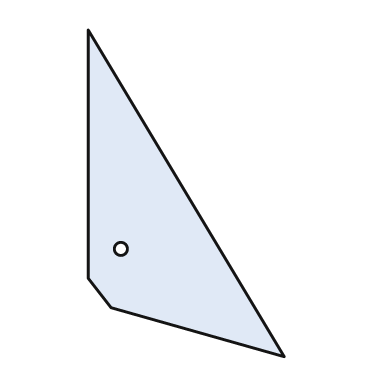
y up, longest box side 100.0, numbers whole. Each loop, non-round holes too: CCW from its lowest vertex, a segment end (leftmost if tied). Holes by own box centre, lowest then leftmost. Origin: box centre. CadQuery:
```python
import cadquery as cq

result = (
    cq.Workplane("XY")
    .moveTo(30.0, -50.0)
    .lineTo(-30.0, 50.0)
    .lineTo(-30.0, -26.0)
    .lineTo(-23.0, -35.0)
    .close()
    .moveTo(-20.0, -17.0)
    .circle(2.0)
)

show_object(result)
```